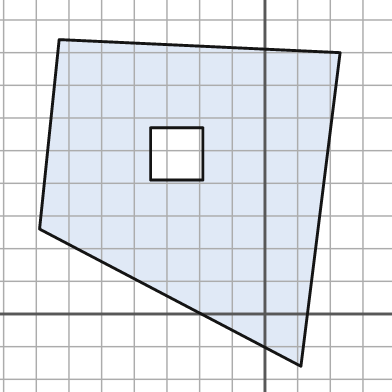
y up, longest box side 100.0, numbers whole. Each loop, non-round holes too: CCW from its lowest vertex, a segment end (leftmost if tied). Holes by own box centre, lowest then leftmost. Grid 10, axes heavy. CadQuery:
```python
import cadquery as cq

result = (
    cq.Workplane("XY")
    .moveTo(11.0, -16.0)
    .lineTo(23.0, 80.0)
    .lineTo(-63.0, 84.0)
    .lineTo(-69.0, 26.0)
    .close()
    .moveTo(-35.0, 41.0)
    .lineTo(-19.0, 41.0)
    .lineTo(-19.0, 57.0)
    .lineTo(-35.0, 57.0)
    .close()
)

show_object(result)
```